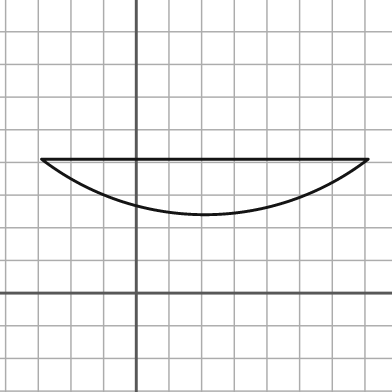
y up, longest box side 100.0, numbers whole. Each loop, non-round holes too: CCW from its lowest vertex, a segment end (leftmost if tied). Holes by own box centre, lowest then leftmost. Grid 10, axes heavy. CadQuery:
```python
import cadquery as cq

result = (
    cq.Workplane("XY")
    .moveTo(-29.0, 41.0)
    .threePointArc((21.0, 24.0), (71.0, 41.0))
    .close()
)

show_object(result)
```